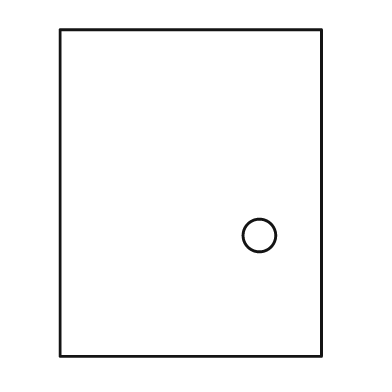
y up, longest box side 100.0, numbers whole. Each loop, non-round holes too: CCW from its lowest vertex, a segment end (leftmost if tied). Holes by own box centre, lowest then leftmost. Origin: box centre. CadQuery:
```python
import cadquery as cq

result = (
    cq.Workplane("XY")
    .moveTo(-40.0, -50.0)
    .lineTo(40.0, -50.0)
    .lineTo(40.0, 50.0)
    .lineTo(-40.0, 50.0)
    .close()
    .moveTo(21.0, -13.0)
    .circle(5.0)
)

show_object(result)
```